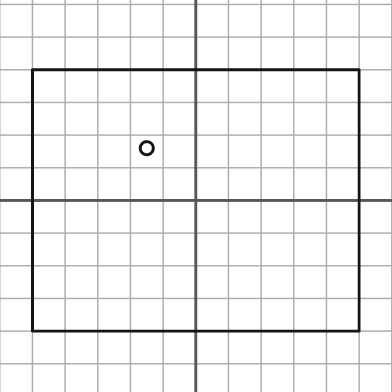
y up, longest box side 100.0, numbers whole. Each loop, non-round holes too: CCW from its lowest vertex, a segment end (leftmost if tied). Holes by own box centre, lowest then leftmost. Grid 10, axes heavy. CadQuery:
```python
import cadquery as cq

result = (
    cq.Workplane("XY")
    .moveTo(-50.0, -40.0)
    .lineTo(50.0, -40.0)
    .lineTo(50.0, 40.0)
    .lineTo(-50.0, 40.0)
    .close()
    .moveTo(-15.0, 16.0)
    .circle(2.0)
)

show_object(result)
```